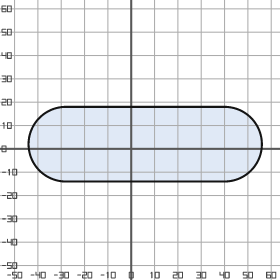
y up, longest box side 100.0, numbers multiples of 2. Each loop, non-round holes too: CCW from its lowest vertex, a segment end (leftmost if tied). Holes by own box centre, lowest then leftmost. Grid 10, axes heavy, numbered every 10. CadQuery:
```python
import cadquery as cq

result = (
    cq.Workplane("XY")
    .moveTo(-28.0, -14.0)
    .lineTo(40.0, -14.0)
    .threePointArc((56.0, 2.0), (40.0, 18.0))
    .lineTo(-28.0, 18.0)
    .threePointArc((-44.0, 2.0), (-28.0, -14.0))
    .close()
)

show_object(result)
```